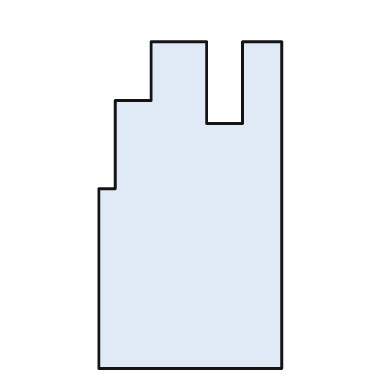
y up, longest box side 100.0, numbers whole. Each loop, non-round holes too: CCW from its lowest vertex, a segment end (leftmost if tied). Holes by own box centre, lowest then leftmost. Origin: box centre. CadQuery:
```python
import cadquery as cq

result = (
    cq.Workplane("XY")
    .moveTo(-28.0, -50.0)
    .lineTo(28.0, -50.0)
    .lineTo(28.0, 50.0)
    .lineTo(16.0, 50.0)
    .lineTo(16.0, 25.0)
    .lineTo(5.0, 25.0)
    .lineTo(5.0, 50.0)
    .lineTo(-12.0, 50.0)
    .lineTo(-12.0, 32.0)
    .lineTo(-23.0, 32.0)
    .lineTo(-23.0, 5.0)
    .lineTo(-28.0, 5.0)
    .close()
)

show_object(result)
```